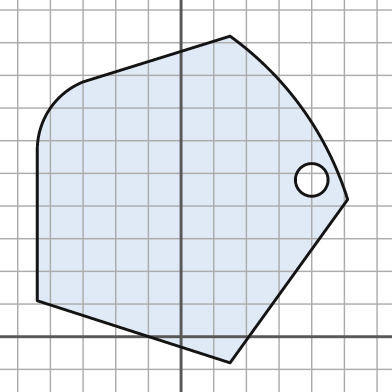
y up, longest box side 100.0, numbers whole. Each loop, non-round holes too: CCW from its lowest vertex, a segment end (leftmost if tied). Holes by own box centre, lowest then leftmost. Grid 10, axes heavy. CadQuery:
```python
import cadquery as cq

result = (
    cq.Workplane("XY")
    .moveTo(15.0, -8.0)
    .lineTo(51.0, 42.0)
    .threePointArc((37.0, 70.0), (15.0, 92.0))
    .lineTo(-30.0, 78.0)
    .threePointArc((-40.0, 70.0), (-44.0, 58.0))
    .lineTo(-44.0, 11.0)
    .close()
    .moveTo(40.0, 48.0)
    .circle(5.0)
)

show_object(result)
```